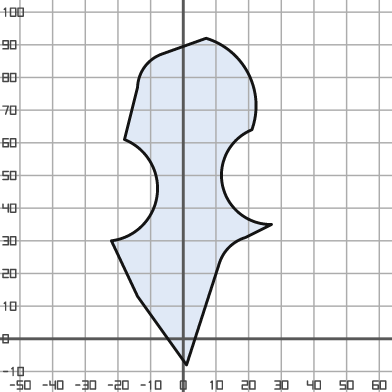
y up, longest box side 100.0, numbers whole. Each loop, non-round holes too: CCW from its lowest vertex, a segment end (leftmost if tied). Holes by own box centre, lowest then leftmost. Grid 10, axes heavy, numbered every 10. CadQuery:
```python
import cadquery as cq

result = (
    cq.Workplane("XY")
    .moveTo(1.0, -8.0)
    .lineTo(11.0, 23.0)
    .threePointArc((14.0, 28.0), (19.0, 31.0))
    .lineTo(27.0, 35.0)
    .threePointArc((12.0, 47.0), (21.0, 64.0))
    .threePointArc((20.0, 81.0), (7.0, 92.0))
    .lineTo(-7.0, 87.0)
    .threePointArc((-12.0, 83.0), (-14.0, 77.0))
    .lineTo(-18.0, 61.0)
    .threePointArc((-8.0, 44.0), (-22.0, 30.0))
    .lineTo(-14.0, 13.0)
    .close()
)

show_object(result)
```